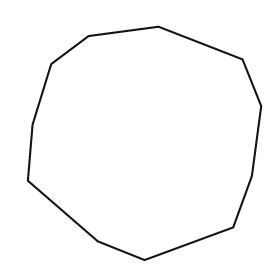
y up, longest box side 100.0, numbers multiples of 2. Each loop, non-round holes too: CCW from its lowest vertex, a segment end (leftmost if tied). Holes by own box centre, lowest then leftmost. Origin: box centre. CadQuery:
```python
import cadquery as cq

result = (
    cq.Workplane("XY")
    .moveTo(0.0, -50.0)
    .lineTo(38.0, -36.0)
    .lineTo(46.0, -14.0)
    .lineTo(50.0, 16.0)
    .lineTo(42.0, 36.0)
    .lineTo(6.0, 50.0)
    .lineTo(-24.0, 46.0)
    .lineTo(-40.0, 34.0)
    .lineTo(-48.0, 8.0)
    .lineTo(-50.0, -16.0)
    .lineTo(-20.0, -42.0)
    .close()
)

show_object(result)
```